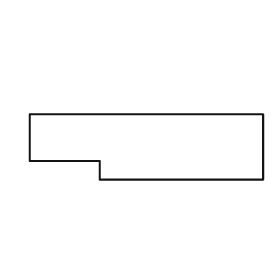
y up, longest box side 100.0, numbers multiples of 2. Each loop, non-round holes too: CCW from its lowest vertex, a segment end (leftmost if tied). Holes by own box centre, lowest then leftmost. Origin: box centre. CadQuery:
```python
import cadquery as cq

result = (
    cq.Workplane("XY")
    .moveTo(-20.0, -14.0)
    .lineTo(50.0, -14.0)
    .lineTo(50.0, 14.0)
    .lineTo(-50.0, 14.0)
    .lineTo(-50.0, -6.0)
    .lineTo(-20.0, -6.0)
    .close()
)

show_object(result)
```